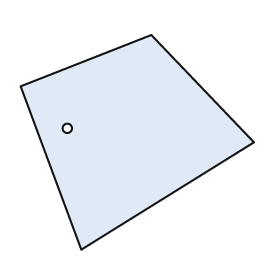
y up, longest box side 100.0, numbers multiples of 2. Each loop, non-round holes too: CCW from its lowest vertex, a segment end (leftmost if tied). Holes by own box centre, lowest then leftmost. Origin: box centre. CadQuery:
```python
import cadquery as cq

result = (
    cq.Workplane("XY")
    .moveTo(-24.0, -46.0)
    .lineTo(50.0, 0.0)
    .lineTo(6.0, 46.0)
    .lineTo(-50.0, 24.0)
    .close()
    .moveTo(-30.0, 6.0)
    .circle(2.0)
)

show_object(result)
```